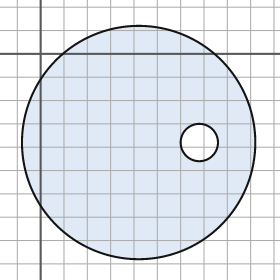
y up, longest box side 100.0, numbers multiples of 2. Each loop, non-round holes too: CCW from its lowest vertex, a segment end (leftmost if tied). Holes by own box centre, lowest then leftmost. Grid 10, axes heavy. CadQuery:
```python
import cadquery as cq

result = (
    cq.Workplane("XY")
    .moveTo(42.0, -38.0)
    .circle(50.0)
    .moveTo(68.0, -38.0)
    .circle(8.0)
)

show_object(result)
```